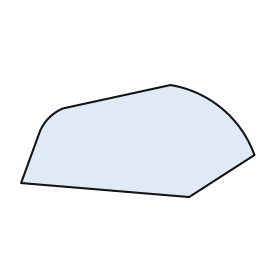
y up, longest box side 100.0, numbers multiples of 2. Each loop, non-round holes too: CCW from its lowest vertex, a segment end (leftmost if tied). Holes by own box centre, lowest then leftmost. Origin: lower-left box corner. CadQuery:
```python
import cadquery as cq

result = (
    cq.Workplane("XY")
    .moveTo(72.0, 0.0)
    .lineTo(100.0, 18.0)
    .threePointArc((86.0, 38.0), (64.0, 48.0))
    .lineTo(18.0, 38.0)
    .threePointArc((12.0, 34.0), (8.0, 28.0))
    .lineTo(0.0, 6.0)
    .close()
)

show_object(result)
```